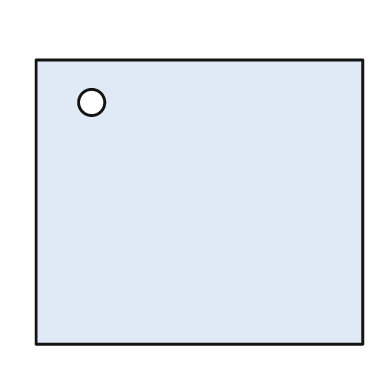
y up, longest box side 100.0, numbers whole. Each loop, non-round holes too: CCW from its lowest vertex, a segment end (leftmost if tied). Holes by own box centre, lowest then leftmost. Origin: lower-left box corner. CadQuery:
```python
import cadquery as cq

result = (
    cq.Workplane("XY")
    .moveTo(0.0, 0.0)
    .lineTo(100.0, 0.0)
    .lineTo(100.0, 87.0)
    .lineTo(0.0, 87.0)
    .close()
    .moveTo(17.0, 74.0)
    .circle(4.0)
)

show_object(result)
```